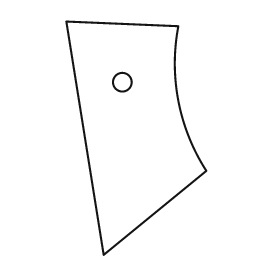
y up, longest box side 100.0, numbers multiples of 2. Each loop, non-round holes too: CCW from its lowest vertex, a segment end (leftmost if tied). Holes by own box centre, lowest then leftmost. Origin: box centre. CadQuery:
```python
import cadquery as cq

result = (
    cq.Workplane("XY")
    .moveTo(-14.0, -50.0)
    .lineTo(30.0, -14.0)
    .threePointArc((18.0, 16.0), (18.0, 48.0))
    .lineTo(-30.0, 50.0)
    .close()
    .moveTo(-6.0, 24.0)
    .circle(4.0)
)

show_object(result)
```